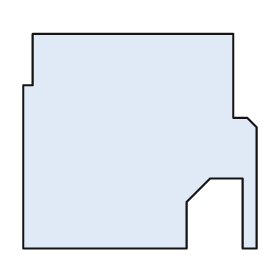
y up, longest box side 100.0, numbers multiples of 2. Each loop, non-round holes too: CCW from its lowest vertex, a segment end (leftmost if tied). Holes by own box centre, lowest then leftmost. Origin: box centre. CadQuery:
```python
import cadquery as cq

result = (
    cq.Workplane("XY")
    .moveTo(-50.0, -46.0)
    .lineTo(20.0, -46.0)
    .lineTo(20.0, -26.0)
    .lineTo(30.0, -16.0)
    .lineTo(44.0, -16.0)
    .lineTo(44.0, -46.0)
    .lineTo(50.0, -46.0)
    .lineTo(50.0, 6.0)
    .lineTo(46.0, 10.0)
    .lineTo(40.0, 10.0)
    .lineTo(40.0, 46.0)
    .lineTo(-46.0, 46.0)
    .lineTo(-46.0, 24.0)
    .lineTo(-50.0, 24.0)
    .close()
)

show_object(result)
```